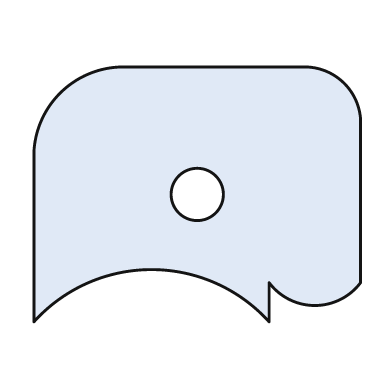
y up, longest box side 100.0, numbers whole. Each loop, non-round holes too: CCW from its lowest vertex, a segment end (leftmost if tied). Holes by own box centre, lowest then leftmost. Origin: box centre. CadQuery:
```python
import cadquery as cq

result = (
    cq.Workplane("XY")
    .moveTo(-50.0, -39.0)
    .threePointArc((-14.0, -23.0), (22.0, -39.0))
    .lineTo(22.0, -27.0)
    .threePointArc((36.0, -34.0), (50.0, -27.0))
    .lineTo(50.0, 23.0)
    .threePointArc((45.0, 34.0), (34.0, 39.0))
    .lineTo(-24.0, 39.0)
    .threePointArc((-42.0, 31.0), (-50.0, 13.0))
    .close()
    .moveTo(0.0, 0.0)
    .circle(8.0)
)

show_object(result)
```